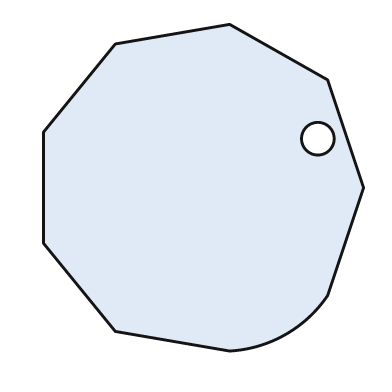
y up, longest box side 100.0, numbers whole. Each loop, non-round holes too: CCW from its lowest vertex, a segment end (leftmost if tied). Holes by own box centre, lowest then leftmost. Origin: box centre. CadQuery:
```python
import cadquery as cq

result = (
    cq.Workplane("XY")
    .moveTo(8.0, -50.0)
    .threePointArc((25.0, -45.0), (38.0, -33.0))
    .lineTo(49.0, 0.0)
    .lineTo(38.0, 33.0)
    .lineTo(8.0, 50.0)
    .lineTo(-27.0, 44.0)
    .lineTo(-49.0, 17.0)
    .lineTo(-49.0, -17.0)
    .lineTo(-27.0, -44.0)
    .close()
    .moveTo(35.0, 15.0)
    .circle(5.0)
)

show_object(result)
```